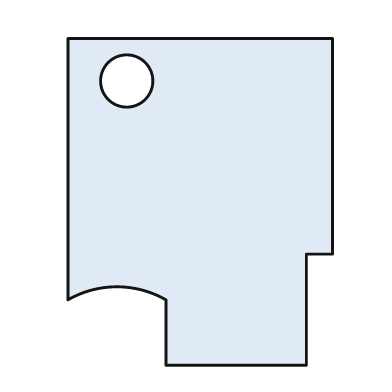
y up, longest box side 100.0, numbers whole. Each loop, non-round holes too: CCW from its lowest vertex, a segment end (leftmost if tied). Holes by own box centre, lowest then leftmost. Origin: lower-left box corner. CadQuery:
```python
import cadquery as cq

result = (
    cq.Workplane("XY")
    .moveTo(30.0, 0.0)
    .lineTo(73.0, 0.0)
    .lineTo(73.0, 34.0)
    .lineTo(81.0, 34.0)
    .lineTo(81.0, 100.0)
    .lineTo(0.0, 100.0)
    .lineTo(0.0, 20.0)
    .threePointArc((15.0, 24.0), (30.0, 20.0))
    .close()
    .moveTo(18.0, 87.0)
    .circle(8.0)
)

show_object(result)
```